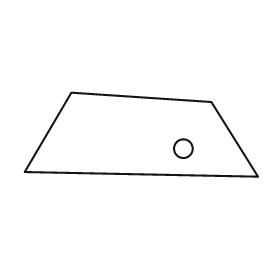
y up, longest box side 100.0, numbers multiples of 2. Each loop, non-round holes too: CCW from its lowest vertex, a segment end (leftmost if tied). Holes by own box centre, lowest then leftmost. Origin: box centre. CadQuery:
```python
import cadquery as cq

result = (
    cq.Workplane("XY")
    .moveTo(50.0, -18.0)
    .lineTo(30.0, 14.0)
    .lineTo(-30.0, 18.0)
    .lineTo(-50.0, -16.0)
    .close()
    .moveTo(18.0, -6.0)
    .circle(4.0)
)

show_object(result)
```